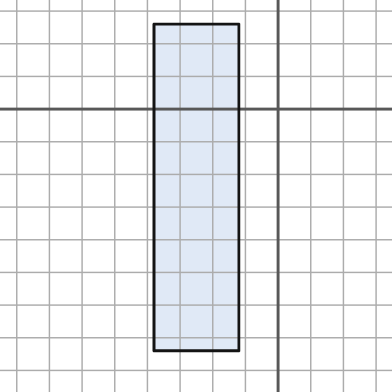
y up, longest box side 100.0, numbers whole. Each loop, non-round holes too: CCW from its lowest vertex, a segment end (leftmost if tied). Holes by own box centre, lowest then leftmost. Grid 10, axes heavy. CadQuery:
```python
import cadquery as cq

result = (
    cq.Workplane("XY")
    .moveTo(-38.0, -74.0)
    .lineTo(-12.0, -74.0)
    .lineTo(-12.0, 26.0)
    .lineTo(-38.0, 26.0)
    .close()
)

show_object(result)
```